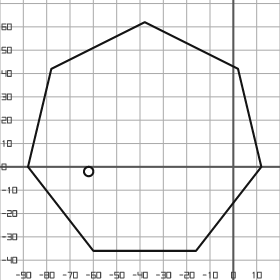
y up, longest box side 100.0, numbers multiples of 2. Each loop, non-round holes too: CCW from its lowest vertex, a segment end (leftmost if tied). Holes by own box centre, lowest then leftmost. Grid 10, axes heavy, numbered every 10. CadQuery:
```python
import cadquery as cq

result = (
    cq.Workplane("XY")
    .moveTo(-60.0, -36.0)
    .lineTo(-16.0, -36.0)
    .lineTo(12.0, 0.0)
    .lineTo(2.0, 42.0)
    .lineTo(-38.0, 62.0)
    .lineTo(-78.0, 42.0)
    .lineTo(-88.0, 0.0)
    .close()
    .moveTo(-62.0, -2.0)
    .circle(2.0)
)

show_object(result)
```